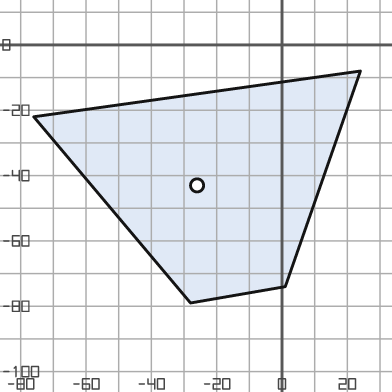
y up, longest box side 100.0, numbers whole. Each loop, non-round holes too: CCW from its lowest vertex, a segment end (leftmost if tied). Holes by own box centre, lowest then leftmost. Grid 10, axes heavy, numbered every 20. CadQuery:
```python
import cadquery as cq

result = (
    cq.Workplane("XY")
    .moveTo(-28.0, -79.0)
    .lineTo(1.0, -74.0)
    .lineTo(24.0, -8.0)
    .lineTo(-76.0, -22.0)
    .close()
    .moveTo(-26.0, -43.0)
    .circle(2.0)
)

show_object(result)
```